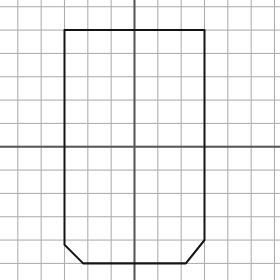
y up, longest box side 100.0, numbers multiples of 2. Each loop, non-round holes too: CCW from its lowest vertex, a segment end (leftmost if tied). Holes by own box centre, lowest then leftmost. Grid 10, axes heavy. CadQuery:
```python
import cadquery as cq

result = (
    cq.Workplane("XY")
    .moveTo(-22.0, -50.0)
    .lineTo(22.0, -50.0)
    .lineTo(30.0, -40.0)
    .lineTo(30.0, 50.0)
    .lineTo(-30.0, 50.0)
    .lineTo(-30.0, -42.0)
    .close()
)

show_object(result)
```